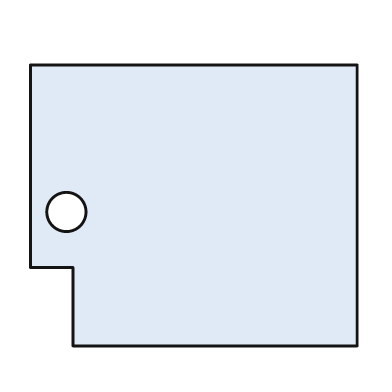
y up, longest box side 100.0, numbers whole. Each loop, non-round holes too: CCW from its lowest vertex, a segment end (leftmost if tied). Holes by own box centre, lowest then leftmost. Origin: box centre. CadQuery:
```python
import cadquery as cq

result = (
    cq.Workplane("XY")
    .moveTo(-37.0, -43.0)
    .lineTo(50.0, -43.0)
    .lineTo(50.0, 43.0)
    .lineTo(-50.0, 43.0)
    .lineTo(-50.0, -19.0)
    .lineTo(-37.0, -19.0)
    .close()
    .moveTo(-39.0, -2.0)
    .circle(6.0)
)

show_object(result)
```